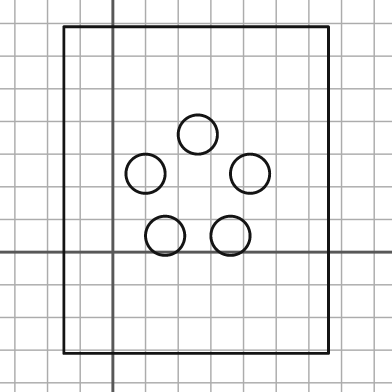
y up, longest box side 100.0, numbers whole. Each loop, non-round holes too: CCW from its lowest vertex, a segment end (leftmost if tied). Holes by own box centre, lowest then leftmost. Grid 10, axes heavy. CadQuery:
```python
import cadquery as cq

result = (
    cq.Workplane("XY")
    .moveTo(-15.0, -31.0)
    .lineTo(66.0, -31.0)
    .lineTo(66.0, 69.0)
    .lineTo(-15.0, 69.0)
    .close()
    .moveTo(16.0, 5.0)
    .circle(6.0)
    .moveTo(36.0, 5.0)
    .circle(6.0)
    .moveTo(10.0, 24.0)
    .circle(6.0)
    .moveTo(42.0, 24.0)
    .circle(6.0)
    .moveTo(26.0, 36.0)
    .circle(6.0)
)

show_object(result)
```